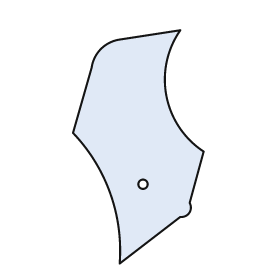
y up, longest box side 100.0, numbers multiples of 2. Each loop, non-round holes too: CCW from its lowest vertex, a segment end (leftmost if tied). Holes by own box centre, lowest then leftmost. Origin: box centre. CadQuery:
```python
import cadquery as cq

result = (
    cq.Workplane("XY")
    .moveTo(-8.0, -50.0)
    .lineTo(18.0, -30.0)
    .threePointArc((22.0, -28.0), (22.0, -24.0))
    .lineTo(28.0, -2.0)
    .threePointArc((12.0, 22.0), (18.0, 50.0))
    .lineTo(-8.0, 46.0)
    .threePointArc((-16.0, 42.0), (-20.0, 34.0))
    .lineTo(-28.0, 6.0)
    .threePointArc((-12.0, -20.0), (-8.0, -50.0))
    .close()
    .moveTo(2.0, -16.0)
    .circle(2.0)
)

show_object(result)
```